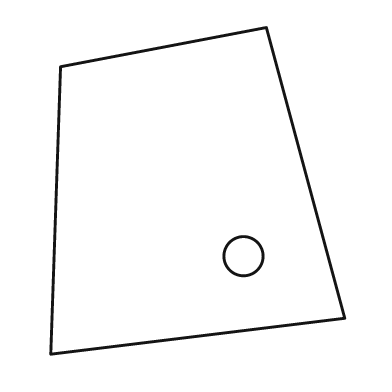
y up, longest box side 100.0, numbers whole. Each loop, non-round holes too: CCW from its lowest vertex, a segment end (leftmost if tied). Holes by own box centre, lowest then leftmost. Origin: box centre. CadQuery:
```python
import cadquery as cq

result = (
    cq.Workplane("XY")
    .moveTo(-45.0, -50.0)
    .lineTo(45.0, -39.0)
    .lineTo(21.0, 50.0)
    .lineTo(-42.0, 38.0)
    .close()
    .moveTo(14.0, -20.0)
    .circle(6.0)
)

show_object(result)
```